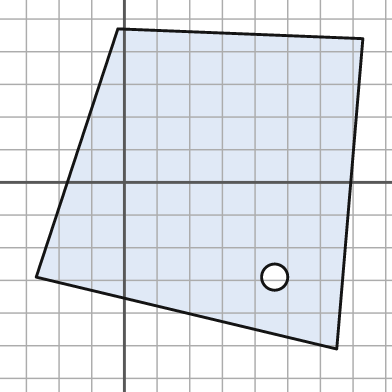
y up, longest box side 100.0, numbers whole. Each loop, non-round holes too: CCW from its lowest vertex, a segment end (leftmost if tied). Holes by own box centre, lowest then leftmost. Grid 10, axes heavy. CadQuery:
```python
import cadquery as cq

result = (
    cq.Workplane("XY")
    .moveTo(65.0, -51.0)
    .lineTo(73.0, 44.0)
    .lineTo(-2.0, 47.0)
    .lineTo(-27.0, -29.0)
    .close()
    .moveTo(46.0, -29.0)
    .circle(4.0)
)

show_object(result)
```